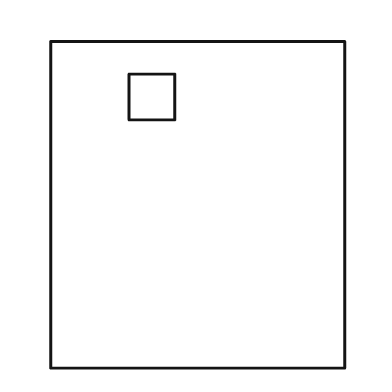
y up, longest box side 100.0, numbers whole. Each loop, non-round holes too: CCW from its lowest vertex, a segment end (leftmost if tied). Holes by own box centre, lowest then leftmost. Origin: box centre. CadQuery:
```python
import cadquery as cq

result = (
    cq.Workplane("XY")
    .moveTo(-45.0, -50.0)
    .lineTo(45.0, -50.0)
    .lineTo(45.0, 50.0)
    .lineTo(-45.0, 50.0)
    .close()
    .moveTo(-21.0, 26.0)
    .lineTo(-7.0, 26.0)
    .lineTo(-7.0, 40.0)
    .lineTo(-21.0, 40.0)
    .close()
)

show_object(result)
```